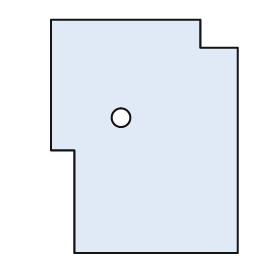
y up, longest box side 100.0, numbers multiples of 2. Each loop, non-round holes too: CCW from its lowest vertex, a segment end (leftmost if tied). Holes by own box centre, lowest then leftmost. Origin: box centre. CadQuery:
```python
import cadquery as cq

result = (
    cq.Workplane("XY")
    .moveTo(-30.0, -50.0)
    .lineTo(40.0, -50.0)
    .lineTo(40.0, 38.0)
    .lineTo(24.0, 38.0)
    .lineTo(24.0, 50.0)
    .lineTo(-40.0, 50.0)
    .lineTo(-40.0, -6.0)
    .lineTo(-30.0, -6.0)
    .close()
    .moveTo(-10.0, 8.0)
    .circle(4.0)
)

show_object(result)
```